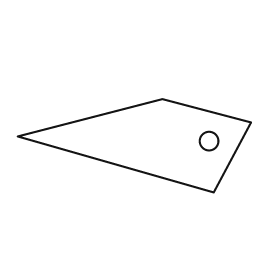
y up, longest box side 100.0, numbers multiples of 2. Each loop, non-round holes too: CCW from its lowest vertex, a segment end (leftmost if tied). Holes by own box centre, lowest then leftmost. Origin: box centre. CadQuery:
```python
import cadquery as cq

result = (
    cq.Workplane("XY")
    .moveTo(34.0, -20.0)
    .lineTo(50.0, 10.0)
    .lineTo(12.0, 20.0)
    .lineTo(-50.0, 4.0)
    .close()
    .moveTo(32.0, 2.0)
    .circle(4.0)
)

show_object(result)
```